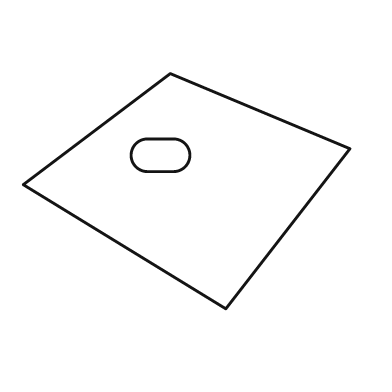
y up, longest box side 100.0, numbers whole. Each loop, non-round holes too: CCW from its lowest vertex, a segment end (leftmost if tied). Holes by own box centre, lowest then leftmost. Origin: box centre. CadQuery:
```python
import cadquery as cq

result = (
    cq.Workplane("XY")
    .moveTo(12.0, -36.0)
    .lineTo(50.0, 13.0)
    .lineTo(-5.0, 36.0)
    .lineTo(-50.0, 2.0)
    .close()
    .moveTo(-12.0, 6.0)
    .lineTo(-4.0, 6.0)
    .threePointArc((1.0, 11.0), (-4.0, 16.0))
    .lineTo(-12.0, 16.0)
    .threePointArc((-17.0, 11.0), (-12.0, 6.0))
    .close()
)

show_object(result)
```